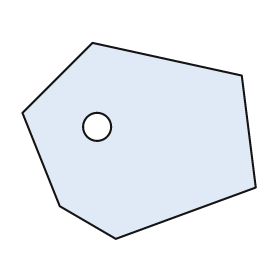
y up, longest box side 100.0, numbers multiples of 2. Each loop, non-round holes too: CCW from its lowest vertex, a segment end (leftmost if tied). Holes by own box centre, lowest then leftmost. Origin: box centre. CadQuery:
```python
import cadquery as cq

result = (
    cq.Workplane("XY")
    .moveTo(-10.0, -42.0)
    .lineTo(50.0, -20.0)
    .lineTo(44.0, 28.0)
    .lineTo(-20.0, 42.0)
    .lineTo(-50.0, 12.0)
    .lineTo(-34.0, -28.0)
    .close()
    .moveTo(-18.0, 6.0)
    .circle(6.0)
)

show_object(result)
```